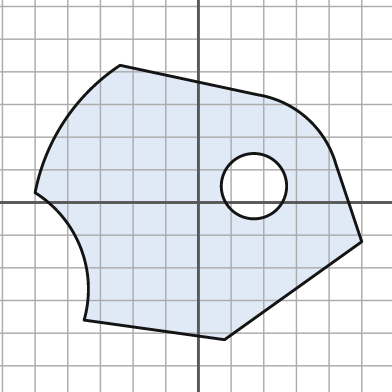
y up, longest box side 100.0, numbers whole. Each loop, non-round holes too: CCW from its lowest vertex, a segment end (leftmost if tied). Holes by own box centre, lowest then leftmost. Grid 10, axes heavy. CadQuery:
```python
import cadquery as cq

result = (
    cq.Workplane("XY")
    .moveTo(8.0, -42.0)
    .lineTo(50.0, -12.0)
    .lineTo(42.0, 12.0)
    .threePointArc((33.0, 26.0), (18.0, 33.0))
    .lineTo(-24.0, 42.0)
    .threePointArc((-41.0, 25.0), (-50.0, 3.0))
    .threePointArc((-36.0, -14.0), (-35.0, -36.0))
    .close()
    .moveTo(17.0, 5.0)
    .circle(10.0)
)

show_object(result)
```